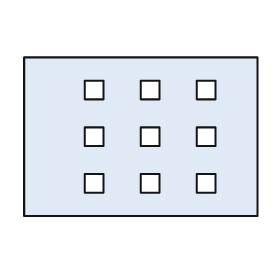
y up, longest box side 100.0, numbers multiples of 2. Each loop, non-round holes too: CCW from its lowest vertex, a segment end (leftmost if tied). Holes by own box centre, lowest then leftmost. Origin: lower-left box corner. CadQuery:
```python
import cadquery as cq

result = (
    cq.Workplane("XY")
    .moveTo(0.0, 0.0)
    .lineTo(100.0, 0.0)
    .lineTo(100.0, 68.0)
    .lineTo(0.0, 68.0)
    .close()
    .moveTo(26.0, 10.0)
    .lineTo(34.0, 10.0)
    .lineTo(34.0, 18.0)
    .lineTo(26.0, 18.0)
    .close()
    .moveTo(50.0, 10.0)
    .lineTo(58.0, 10.0)
    .lineTo(58.0, 18.0)
    .lineTo(50.0, 18.0)
    .close()
    .moveTo(74.0, 10.0)
    .lineTo(82.0, 10.0)
    .lineTo(82.0, 18.0)
    .lineTo(74.0, 18.0)
    .close()
    .moveTo(26.0, 30.0)
    .lineTo(34.0, 30.0)
    .lineTo(34.0, 38.0)
    .lineTo(26.0, 38.0)
    .close()
    .moveTo(50.0, 30.0)
    .lineTo(58.0, 30.0)
    .lineTo(58.0, 38.0)
    .lineTo(50.0, 38.0)
    .close()
    .moveTo(74.0, 30.0)
    .lineTo(82.0, 30.0)
    .lineTo(82.0, 38.0)
    .lineTo(74.0, 38.0)
    .close()
    .moveTo(26.0, 50.0)
    .lineTo(34.0, 50.0)
    .lineTo(34.0, 58.0)
    .lineTo(26.0, 58.0)
    .close()
    .moveTo(50.0, 50.0)
    .lineTo(58.0, 50.0)
    .lineTo(58.0, 58.0)
    .lineTo(50.0, 58.0)
    .close()
    .moveTo(74.0, 50.0)
    .lineTo(82.0, 50.0)
    .lineTo(82.0, 58.0)
    .lineTo(74.0, 58.0)
    .close()
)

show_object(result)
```